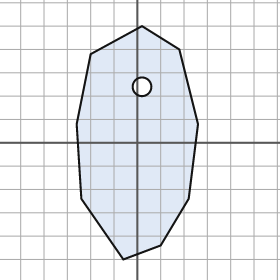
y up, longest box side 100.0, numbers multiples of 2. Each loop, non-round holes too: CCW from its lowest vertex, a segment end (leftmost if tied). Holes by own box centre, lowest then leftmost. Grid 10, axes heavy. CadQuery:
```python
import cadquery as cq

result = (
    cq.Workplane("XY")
    .moveTo(-6.0, -50.0)
    .lineTo(10.0, -44.0)
    .lineTo(22.0, -24.0)
    .lineTo(26.0, 8.0)
    .lineTo(18.0, 40.0)
    .lineTo(2.0, 50.0)
    .lineTo(-20.0, 38.0)
    .lineTo(-26.0, 8.0)
    .lineTo(-24.0, -24.0)
    .close()
    .moveTo(2.0, 24.0)
    .circle(4.0)
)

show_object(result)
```